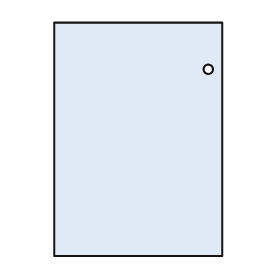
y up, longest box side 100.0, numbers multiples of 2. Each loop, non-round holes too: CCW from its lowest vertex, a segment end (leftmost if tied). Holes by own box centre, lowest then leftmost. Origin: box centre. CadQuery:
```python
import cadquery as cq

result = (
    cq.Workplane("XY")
    .moveTo(-36.0, -50.0)
    .lineTo(36.0, -50.0)
    .lineTo(36.0, 50.0)
    .lineTo(-36.0, 50.0)
    .close()
    .moveTo(30.0, 30.0)
    .circle(2.0)
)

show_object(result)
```